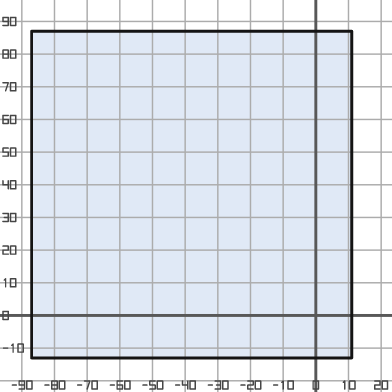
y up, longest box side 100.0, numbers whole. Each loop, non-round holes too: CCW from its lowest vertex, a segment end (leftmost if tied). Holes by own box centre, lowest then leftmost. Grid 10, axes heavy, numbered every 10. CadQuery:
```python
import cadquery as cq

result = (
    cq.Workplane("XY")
    .moveTo(-87.0, -13.0)
    .lineTo(11.0, -13.0)
    .lineTo(11.0, 87.0)
    .lineTo(-87.0, 87.0)
    .close()
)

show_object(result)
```